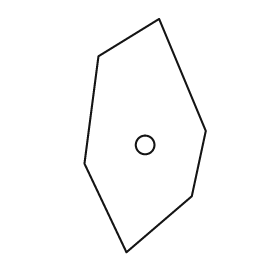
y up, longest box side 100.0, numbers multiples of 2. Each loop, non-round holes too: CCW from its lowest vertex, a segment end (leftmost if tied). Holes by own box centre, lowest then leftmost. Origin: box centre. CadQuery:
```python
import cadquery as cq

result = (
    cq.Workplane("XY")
    .moveTo(-8.0, -50.0)
    .lineTo(20.0, -26.0)
    .lineTo(26.0, 2.0)
    .lineTo(6.0, 50.0)
    .lineTo(-20.0, 34.0)
    .lineTo(-26.0, -12.0)
    .close()
    .moveTo(0.0, -4.0)
    .circle(4.0)
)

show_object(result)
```